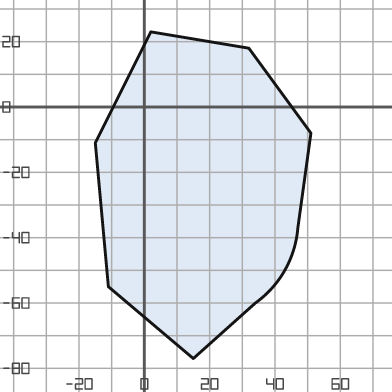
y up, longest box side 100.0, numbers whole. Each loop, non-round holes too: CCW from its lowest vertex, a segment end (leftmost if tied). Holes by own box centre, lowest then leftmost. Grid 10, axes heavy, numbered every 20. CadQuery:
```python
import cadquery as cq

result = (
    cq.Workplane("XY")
    .moveTo(15.0, -77.0)
    .lineTo(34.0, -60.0)
    .threePointArc((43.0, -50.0), (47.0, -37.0))
    .lineTo(51.0, -8.0)
    .lineTo(32.0, 18.0)
    .lineTo(2.0, 23.0)
    .lineTo(-15.0, -11.0)
    .lineTo(-11.0, -55.0)
    .close()
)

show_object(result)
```